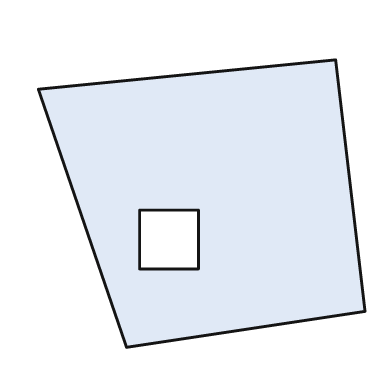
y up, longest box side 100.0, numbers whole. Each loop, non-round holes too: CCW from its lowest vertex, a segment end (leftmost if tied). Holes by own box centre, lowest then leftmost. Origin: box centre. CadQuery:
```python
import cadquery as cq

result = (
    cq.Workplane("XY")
    .moveTo(-23.0, -44.0)
    .lineTo(50.0, -33.0)
    .lineTo(41.0, 44.0)
    .lineTo(-50.0, 35.0)
    .close()
    .moveTo(-19.0, -20.0)
    .lineTo(-1.0, -20.0)
    .lineTo(-1.0, -2.0)
    .lineTo(-19.0, -2.0)
    .close()
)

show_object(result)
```